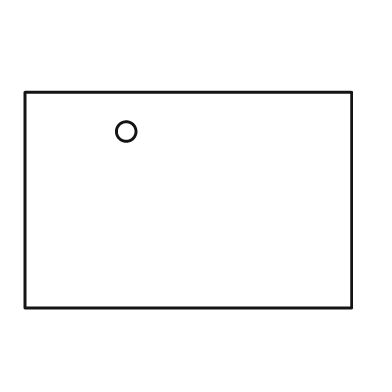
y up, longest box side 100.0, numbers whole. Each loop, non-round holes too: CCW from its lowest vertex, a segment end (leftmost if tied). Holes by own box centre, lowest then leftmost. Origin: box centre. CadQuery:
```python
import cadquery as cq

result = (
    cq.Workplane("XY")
    .moveTo(-50.0, -33.0)
    .lineTo(50.0, -33.0)
    .lineTo(50.0, 33.0)
    .lineTo(-50.0, 33.0)
    .close()
    .moveTo(-19.0, 21.0)
    .circle(3.0)
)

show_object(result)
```